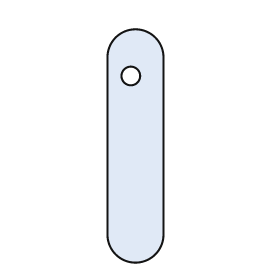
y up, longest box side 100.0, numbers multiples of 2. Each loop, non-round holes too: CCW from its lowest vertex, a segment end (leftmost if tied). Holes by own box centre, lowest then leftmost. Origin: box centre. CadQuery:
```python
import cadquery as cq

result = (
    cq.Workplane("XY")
    .moveTo(-12.0, -38.0)
    .threePointArc((0.0, -50.0), (12.0, -38.0))
    .lineTo(12.0, 38.0)
    .threePointArc((0.0, 50.0), (-12.0, 38.0))
    .close()
    .moveTo(-2.0, 30.0)
    .circle(4.0)
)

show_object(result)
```